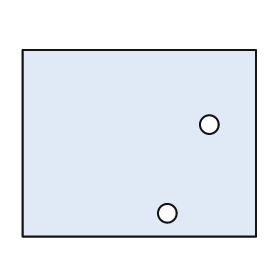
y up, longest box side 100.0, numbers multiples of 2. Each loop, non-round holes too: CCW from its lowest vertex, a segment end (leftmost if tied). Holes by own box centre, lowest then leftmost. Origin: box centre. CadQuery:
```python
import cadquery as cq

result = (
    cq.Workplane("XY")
    .moveTo(-50.0, -40.0)
    .lineTo(50.0, -40.0)
    .lineTo(50.0, 40.0)
    .lineTo(-50.0, 40.0)
    .close()
    .moveTo(12.0, -30.0)
    .circle(4.0)
    .moveTo(30.0, 8.0)
    .circle(4.0)
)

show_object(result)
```